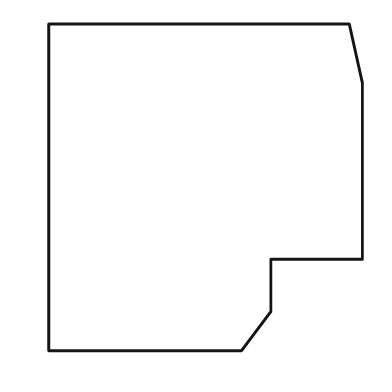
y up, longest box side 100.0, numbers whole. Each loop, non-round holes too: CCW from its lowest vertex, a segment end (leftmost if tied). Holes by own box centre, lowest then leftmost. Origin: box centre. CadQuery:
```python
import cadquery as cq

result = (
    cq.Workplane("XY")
    .moveTo(-48.0, -50.0)
    .lineTo(11.0, -50.0)
    .lineTo(20.0, -38.0)
    .lineTo(20.0, -22.0)
    .lineTo(48.0, -22.0)
    .lineTo(48.0, 32.0)
    .lineTo(44.0, 50.0)
    .lineTo(-48.0, 50.0)
    .close()
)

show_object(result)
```